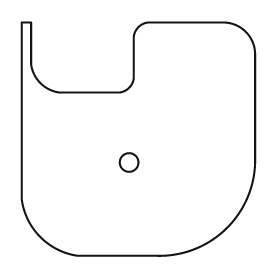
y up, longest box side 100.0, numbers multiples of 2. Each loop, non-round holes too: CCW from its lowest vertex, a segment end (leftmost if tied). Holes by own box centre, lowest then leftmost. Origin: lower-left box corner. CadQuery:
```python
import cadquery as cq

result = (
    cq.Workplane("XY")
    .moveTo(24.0, 0.0)
    .lineTo(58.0, 0.0)
    .threePointArc((88.0, 12.0), (100.0, 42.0))
    .lineTo(100.0, 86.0)
    .threePointArc((96.0, 96.0), (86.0, 100.0))
    .lineTo(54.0, 100.0)
    .threePointArc((50.0, 98.0), (48.0, 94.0))
    .lineTo(48.0, 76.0)
    .threePointArc((46.0, 72.0), (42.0, 70.0))
    .lineTo(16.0, 70.0)
    .threePointArc((8.0, 74.0), (4.0, 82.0))
    .lineTo(4.0, 100.0)
    .lineTo(0.0, 100.0)
    .lineTo(0.0, 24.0)
    .threePointArc((8.0, 8.0), (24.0, 0.0))
    .close()
    .moveTo(46.0, 40.0)
    .circle(4.0)
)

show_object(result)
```